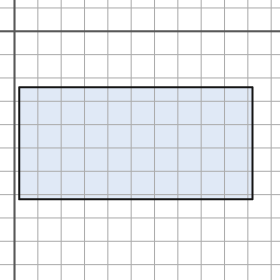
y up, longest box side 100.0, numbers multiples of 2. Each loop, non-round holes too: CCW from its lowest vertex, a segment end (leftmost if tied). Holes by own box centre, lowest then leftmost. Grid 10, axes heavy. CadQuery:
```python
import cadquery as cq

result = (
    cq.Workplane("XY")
    .moveTo(2.0, -72.0)
    .lineTo(102.0, -72.0)
    .lineTo(102.0, -24.0)
    .lineTo(2.0, -24.0)
    .close()
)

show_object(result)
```